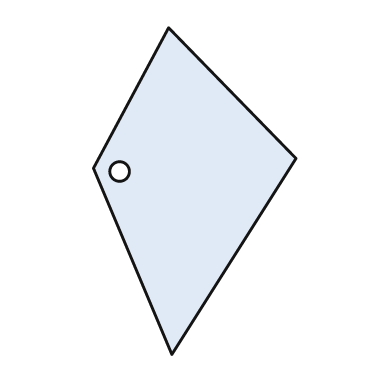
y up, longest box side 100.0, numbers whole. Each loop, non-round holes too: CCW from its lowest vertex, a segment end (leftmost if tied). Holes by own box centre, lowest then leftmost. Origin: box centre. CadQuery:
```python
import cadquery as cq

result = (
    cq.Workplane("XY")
    .moveTo(-7.0, -50.0)
    .lineTo(31.0, 10.0)
    .lineTo(-8.0, 50.0)
    .lineTo(-31.0, 7.0)
    .close()
    .moveTo(-23.0, 6.0)
    .circle(3.0)
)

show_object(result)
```